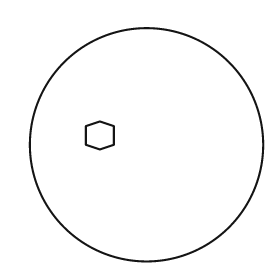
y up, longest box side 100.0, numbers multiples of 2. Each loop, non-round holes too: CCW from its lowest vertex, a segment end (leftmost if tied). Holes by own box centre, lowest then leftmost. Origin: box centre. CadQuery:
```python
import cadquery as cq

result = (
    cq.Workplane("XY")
    .moveTo(0.0, 0.0)
    .circle(50.0)
    .moveTo(-20.0, -2.0)
    .lineTo(-14.0, 0.0)
    .lineTo(-14.0, 8.0)
    .lineTo(-20.0, 10.0)
    .lineTo(-26.0, 8.0)
    .lineTo(-26.0, 0.0)
    .close()
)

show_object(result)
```